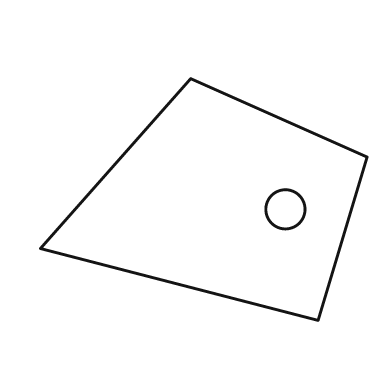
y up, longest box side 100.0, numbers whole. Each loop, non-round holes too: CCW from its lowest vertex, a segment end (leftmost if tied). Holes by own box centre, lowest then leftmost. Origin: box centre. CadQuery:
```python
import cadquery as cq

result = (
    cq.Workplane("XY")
    .moveTo(35.0, -37.0)
    .lineTo(50.0, 13.0)
    .lineTo(-4.0, 37.0)
    .lineTo(-50.0, -15.0)
    .close()
    .moveTo(25.0, -3.0)
    .circle(6.0)
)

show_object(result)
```